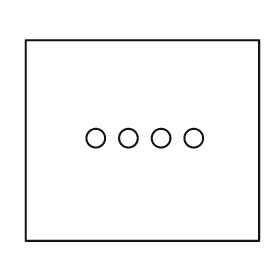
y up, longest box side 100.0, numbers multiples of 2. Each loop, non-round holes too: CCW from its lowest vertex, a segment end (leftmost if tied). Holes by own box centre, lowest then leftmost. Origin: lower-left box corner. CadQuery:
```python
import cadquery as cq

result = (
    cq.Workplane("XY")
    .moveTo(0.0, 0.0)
    .lineTo(100.0, 0.0)
    .lineTo(100.0, 86.0)
    .lineTo(0.0, 86.0)
    .close()
    .moveTo(30.0, 44.0)
    .circle(4.0)
    .moveTo(44.0, 44.0)
    .circle(4.0)
    .moveTo(58.0, 44.0)
    .circle(4.0)
    .moveTo(72.0, 44.0)
    .circle(4.0)
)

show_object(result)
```